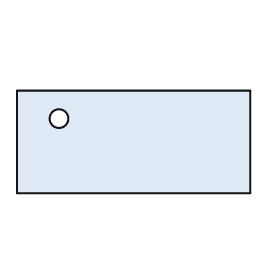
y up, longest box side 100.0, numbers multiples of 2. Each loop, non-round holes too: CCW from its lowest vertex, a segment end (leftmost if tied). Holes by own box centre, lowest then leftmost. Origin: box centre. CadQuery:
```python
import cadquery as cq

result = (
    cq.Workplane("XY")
    .moveTo(-50.0, -22.0)
    .lineTo(50.0, -22.0)
    .lineTo(50.0, 22.0)
    .lineTo(-50.0, 22.0)
    .close()
    .moveTo(-32.0, 10.0)
    .circle(4.0)
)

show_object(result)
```